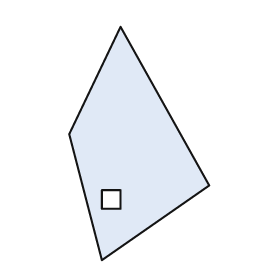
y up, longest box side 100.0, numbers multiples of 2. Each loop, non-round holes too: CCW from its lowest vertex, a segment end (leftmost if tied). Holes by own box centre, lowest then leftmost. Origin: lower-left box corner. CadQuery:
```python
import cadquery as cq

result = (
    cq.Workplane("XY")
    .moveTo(14.0, 0.0)
    .lineTo(60.0, 32.0)
    .lineTo(22.0, 100.0)
    .lineTo(0.0, 54.0)
    .close()
    .moveTo(14.0, 22.0)
    .lineTo(22.0, 22.0)
    .lineTo(22.0, 30.0)
    .lineTo(14.0, 30.0)
    .close()
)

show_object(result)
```